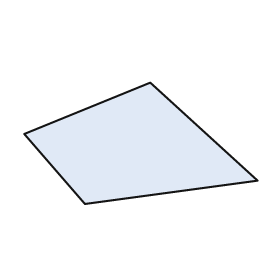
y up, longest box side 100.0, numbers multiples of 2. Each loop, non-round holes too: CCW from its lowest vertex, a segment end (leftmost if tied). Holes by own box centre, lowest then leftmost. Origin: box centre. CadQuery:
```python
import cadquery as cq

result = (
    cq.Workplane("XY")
    .moveTo(-24.0, -26.0)
    .lineTo(50.0, -16.0)
    .lineTo(4.0, 26.0)
    .lineTo(-50.0, 4.0)
    .close()
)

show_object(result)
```